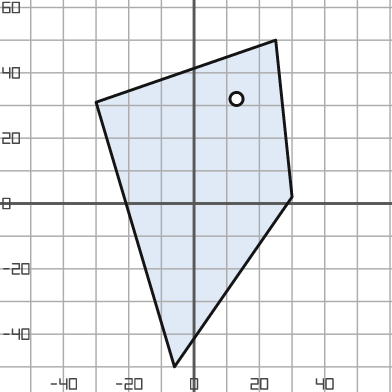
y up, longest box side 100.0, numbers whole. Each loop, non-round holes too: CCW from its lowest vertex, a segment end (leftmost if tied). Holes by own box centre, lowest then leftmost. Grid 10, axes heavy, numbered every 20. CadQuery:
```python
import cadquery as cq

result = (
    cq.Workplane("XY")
    .moveTo(-6.0, -50.0)
    .lineTo(30.0, 2.0)
    .lineTo(25.0, 50.0)
    .lineTo(-30.0, 31.0)
    .close()
    .moveTo(13.0, 32.0)
    .circle(2.0)
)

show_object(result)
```